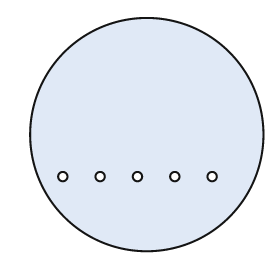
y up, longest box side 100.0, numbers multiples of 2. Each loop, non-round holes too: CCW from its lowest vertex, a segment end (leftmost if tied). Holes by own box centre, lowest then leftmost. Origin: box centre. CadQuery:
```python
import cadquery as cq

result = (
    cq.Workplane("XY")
    .moveTo(0.0, 0.0)
    .circle(50.0)
    .moveTo(-36.0, -18.0)
    .circle(2.0)
    .moveTo(-20.0, -18.0)
    .circle(2.0)
    .moveTo(-4.0, -18.0)
    .circle(2.0)
    .moveTo(12.0, -18.0)
    .circle(2.0)
    .moveTo(28.0, -18.0)
    .circle(2.0)
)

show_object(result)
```